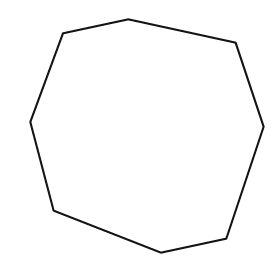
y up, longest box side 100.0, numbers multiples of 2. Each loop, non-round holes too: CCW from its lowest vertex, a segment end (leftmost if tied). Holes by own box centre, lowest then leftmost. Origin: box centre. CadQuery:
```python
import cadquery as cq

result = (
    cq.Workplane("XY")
    .moveTo(6.0, -50.0)
    .lineTo(34.0, -44.0)
    .lineTo(50.0, 4.0)
    .lineTo(38.0, 40.0)
    .lineTo(-8.0, 50.0)
    .lineTo(-36.0, 44.0)
    .lineTo(-50.0, 6.0)
    .lineTo(-40.0, -32.0)
    .close()
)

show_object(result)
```